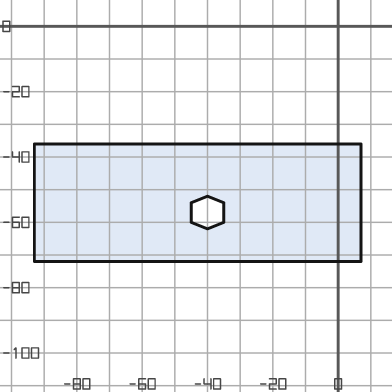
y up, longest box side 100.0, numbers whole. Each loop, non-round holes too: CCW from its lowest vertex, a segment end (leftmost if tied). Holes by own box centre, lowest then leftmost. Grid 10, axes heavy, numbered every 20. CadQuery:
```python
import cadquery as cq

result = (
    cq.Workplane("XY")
    .moveTo(-93.0, -72.0)
    .lineTo(7.0, -72.0)
    .lineTo(7.0, -36.0)
    .lineTo(-93.0, -36.0)
    .close()
    .moveTo(-40.0, -62.0)
    .lineTo(-35.0, -60.0)
    .lineTo(-35.0, -54.0)
    .lineTo(-40.0, -52.0)
    .lineTo(-45.0, -54.0)
    .lineTo(-45.0, -60.0)
    .close()
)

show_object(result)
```